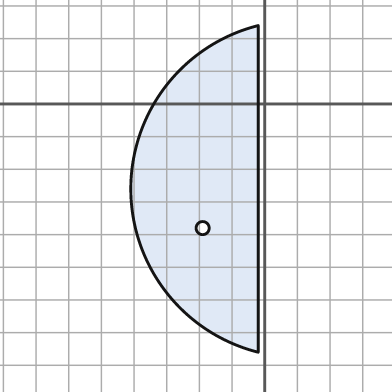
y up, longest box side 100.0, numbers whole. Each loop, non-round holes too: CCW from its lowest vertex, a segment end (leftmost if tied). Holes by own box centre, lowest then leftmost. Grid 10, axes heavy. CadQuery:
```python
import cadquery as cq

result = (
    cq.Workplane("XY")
    .moveTo(-2.0, -76.0)
    .lineTo(-2.0, 24.0)
    .threePointArc((-41.0, -26.0), (-2.0, -76.0))
    .close()
    .moveTo(-19.0, -38.0)
    .circle(2.0)
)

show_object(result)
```